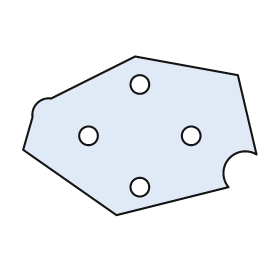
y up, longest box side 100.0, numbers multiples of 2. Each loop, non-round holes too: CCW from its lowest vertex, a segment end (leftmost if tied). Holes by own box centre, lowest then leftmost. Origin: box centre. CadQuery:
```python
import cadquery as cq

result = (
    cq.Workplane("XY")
    .moveTo(-10.0, -34.0)
    .lineTo(38.0, -22.0)
    .threePointArc((38.0, -10.0), (50.0, -8.0))
    .lineTo(42.0, 26.0)
    .lineTo(-2.0, 34.0)
    .lineTo(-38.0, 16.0)
    .threePointArc((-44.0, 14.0), (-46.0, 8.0))
    .lineTo(-50.0, -6.0)
    .close()
    .moveTo(0.0, -22.0)
    .circle(4.0)
    .moveTo(-22.0, 0.0)
    .circle(4.0)
    .moveTo(22.0, 0.0)
    .circle(4.0)
    .moveTo(0.0, 22.0)
    .circle(4.0)
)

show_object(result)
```